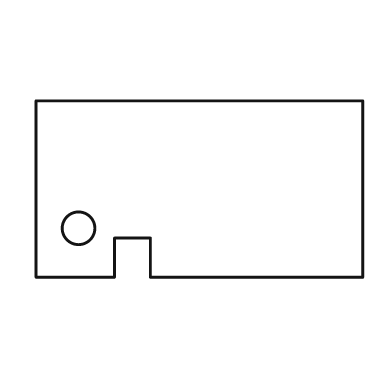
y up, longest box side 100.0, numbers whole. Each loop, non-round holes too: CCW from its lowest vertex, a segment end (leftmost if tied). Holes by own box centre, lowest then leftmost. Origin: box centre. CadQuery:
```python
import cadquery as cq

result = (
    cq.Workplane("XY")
    .moveTo(-50.0, -27.0)
    .lineTo(-26.0, -27.0)
    .lineTo(-26.0, -15.0)
    .lineTo(-15.0, -15.0)
    .lineTo(-15.0, -27.0)
    .lineTo(50.0, -27.0)
    .lineTo(50.0, 27.0)
    .lineTo(-50.0, 27.0)
    .close()
    .moveTo(-37.0, -12.0)
    .circle(5.0)
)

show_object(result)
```